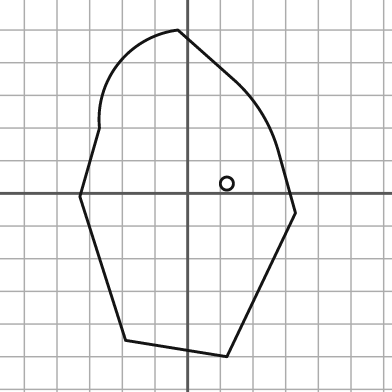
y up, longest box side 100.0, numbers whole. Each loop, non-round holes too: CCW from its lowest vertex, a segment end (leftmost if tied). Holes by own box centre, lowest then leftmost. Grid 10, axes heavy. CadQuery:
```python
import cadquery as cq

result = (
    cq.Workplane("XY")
    .moveTo(12.0, -50.0)
    .lineTo(33.0, -6.0)
    .lineTo(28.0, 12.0)
    .threePointArc((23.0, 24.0), (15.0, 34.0))
    .lineTo(-3.0, 50.0)
    .threePointArc((-21.0, 40.0), (-27.0, 20.0))
    .lineTo(-33.0, -1.0)
    .lineTo(-19.0, -45.0)
    .close()
    .moveTo(12.0, 3.0)
    .circle(2.0)
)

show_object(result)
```